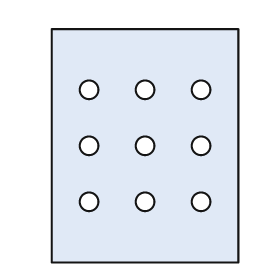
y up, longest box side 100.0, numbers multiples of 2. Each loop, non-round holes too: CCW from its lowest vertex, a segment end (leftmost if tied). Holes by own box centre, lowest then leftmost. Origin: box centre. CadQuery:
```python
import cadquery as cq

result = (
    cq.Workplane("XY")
    .moveTo(-40.0, -50.0)
    .lineTo(40.0, -50.0)
    .lineTo(40.0, 50.0)
    .lineTo(-40.0, 50.0)
    .close()
    .moveTo(-24.0, -24.0)
    .circle(4.0)
    .moveTo(0.0, -24.0)
    .circle(4.0)
    .moveTo(24.0, -24.0)
    .circle(4.0)
    .moveTo(-24.0, 0.0)
    .circle(4.0)
    .moveTo(0.0, 0.0)
    .circle(4.0)
    .moveTo(24.0, 0.0)
    .circle(4.0)
    .moveTo(-24.0, 24.0)
    .circle(4.0)
    .moveTo(0.0, 24.0)
    .circle(4.0)
    .moveTo(24.0, 24.0)
    .circle(4.0)
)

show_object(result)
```